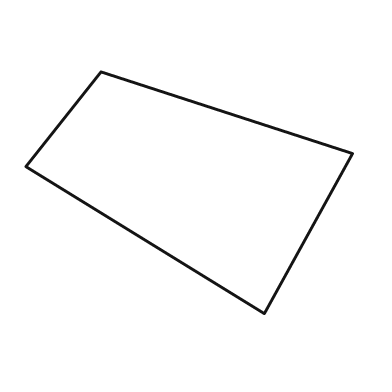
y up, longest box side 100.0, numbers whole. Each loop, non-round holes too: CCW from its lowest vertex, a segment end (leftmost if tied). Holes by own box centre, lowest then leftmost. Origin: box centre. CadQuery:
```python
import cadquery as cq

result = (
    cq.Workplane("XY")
    .moveTo(23.0, -37.0)
    .lineTo(50.0, 12.0)
    .lineTo(-27.0, 37.0)
    .lineTo(-50.0, 8.0)
    .close()
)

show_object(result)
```